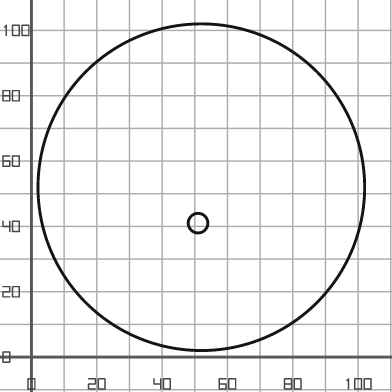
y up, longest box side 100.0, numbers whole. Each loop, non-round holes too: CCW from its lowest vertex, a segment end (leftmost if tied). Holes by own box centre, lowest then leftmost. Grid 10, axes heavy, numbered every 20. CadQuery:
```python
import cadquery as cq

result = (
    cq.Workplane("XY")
    .moveTo(52.0, 52.0)
    .circle(50.0)
    .moveTo(51.0, 41.0)
    .circle(3.0)
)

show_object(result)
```